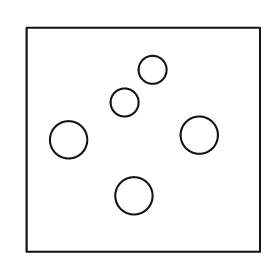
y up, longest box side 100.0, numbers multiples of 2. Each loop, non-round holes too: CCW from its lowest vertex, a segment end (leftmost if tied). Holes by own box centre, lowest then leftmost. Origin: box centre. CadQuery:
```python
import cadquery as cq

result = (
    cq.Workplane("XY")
    .moveTo(-50.0, -48.0)
    .lineTo(50.0, -48.0)
    .lineTo(50.0, 48.0)
    .lineTo(-50.0, 48.0)
    .close()
    .moveTo(-4.0, -24.0)
    .circle(8.0)
    .moveTo(-32.0, 0.0)
    .circle(8.0)
    .moveTo(24.0, 2.0)
    .circle(8.0)
    .moveTo(-8.0, 16.0)
    .circle(6.0)
    .moveTo(4.0, 30.0)
    .circle(6.0)
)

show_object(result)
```